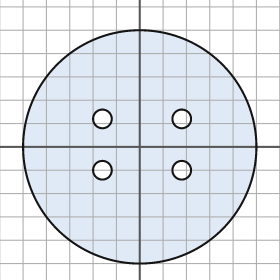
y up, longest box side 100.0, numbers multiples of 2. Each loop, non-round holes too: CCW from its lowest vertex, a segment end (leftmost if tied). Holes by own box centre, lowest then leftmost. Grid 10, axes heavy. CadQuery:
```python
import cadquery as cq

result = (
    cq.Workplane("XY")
    .moveTo(0.0, 0.0)
    .circle(50.0)
    .moveTo(-16.0, -10.0)
    .circle(4.0)
    .moveTo(18.0, -10.0)
    .circle(4.0)
    .moveTo(-16.0, 12.0)
    .circle(4.0)
    .moveTo(18.0, 12.0)
    .circle(4.0)
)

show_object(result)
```